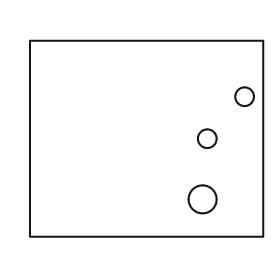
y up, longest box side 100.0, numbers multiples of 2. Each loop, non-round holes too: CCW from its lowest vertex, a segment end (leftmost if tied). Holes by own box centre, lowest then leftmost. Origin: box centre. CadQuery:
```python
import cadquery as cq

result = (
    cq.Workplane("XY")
    .moveTo(-50.0, -42.0)
    .lineTo(50.0, -42.0)
    .lineTo(50.0, 42.0)
    .lineTo(-50.0, 42.0)
    .close()
    .moveTo(24.0, -26.0)
    .circle(6.0)
    .moveTo(26.0, 0.0)
    .circle(4.0)
    .moveTo(42.0, 18.0)
    .circle(4.0)
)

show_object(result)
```